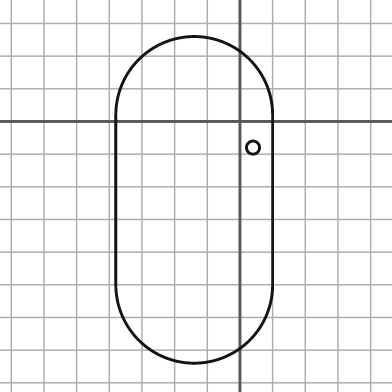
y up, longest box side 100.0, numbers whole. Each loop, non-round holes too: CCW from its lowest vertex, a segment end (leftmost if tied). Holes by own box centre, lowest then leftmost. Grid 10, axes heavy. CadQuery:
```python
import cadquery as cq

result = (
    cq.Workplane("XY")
    .moveTo(-38.0, -50.0)
    .threePointArc((-14.0, -74.0), (10.0, -50.0))
    .lineTo(10.0, 2.0)
    .threePointArc((-14.0, 26.0), (-38.0, 2.0))
    .close()
    .moveTo(4.0, -8.0)
    .circle(2.0)
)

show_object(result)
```